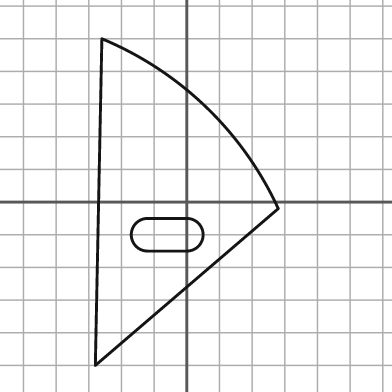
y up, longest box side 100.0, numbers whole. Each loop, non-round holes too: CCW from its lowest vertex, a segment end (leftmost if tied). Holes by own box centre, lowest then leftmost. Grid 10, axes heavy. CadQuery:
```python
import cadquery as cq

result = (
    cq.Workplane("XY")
    .moveTo(-28.0, -50.0)
    .lineTo(28.0, -2.0)
    .threePointArc((6.0, 29.0), (-26.0, 50.0))
    .close()
    .moveTo(-12.0, -15.0)
    .lineTo(0.0, -15.0)
    .threePointArc((5.0, -10.0), (0.0, -5.0))
    .lineTo(-12.0, -5.0)
    .threePointArc((-17.0, -10.0), (-12.0, -15.0))
    .close()
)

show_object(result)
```